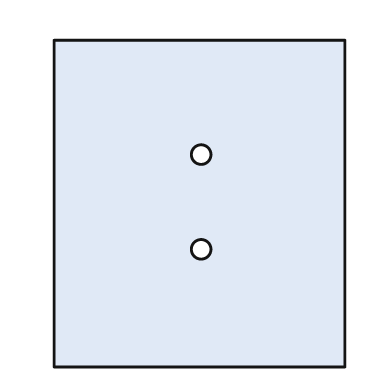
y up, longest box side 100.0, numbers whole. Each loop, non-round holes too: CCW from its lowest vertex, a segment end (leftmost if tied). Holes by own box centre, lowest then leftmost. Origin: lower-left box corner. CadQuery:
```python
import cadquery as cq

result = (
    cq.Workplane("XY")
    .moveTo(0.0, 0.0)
    .lineTo(89.0, 0.0)
    .lineTo(89.0, 100.0)
    .lineTo(0.0, 100.0)
    .close()
    .moveTo(45.0, 36.0)
    .circle(3.0)
    .moveTo(45.0, 65.0)
    .circle(3.0)
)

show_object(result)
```